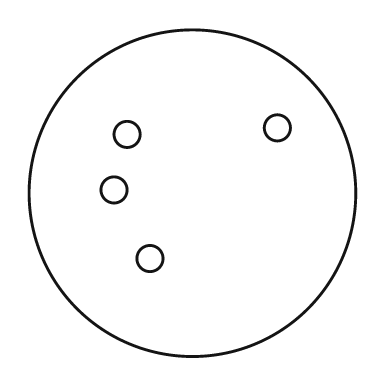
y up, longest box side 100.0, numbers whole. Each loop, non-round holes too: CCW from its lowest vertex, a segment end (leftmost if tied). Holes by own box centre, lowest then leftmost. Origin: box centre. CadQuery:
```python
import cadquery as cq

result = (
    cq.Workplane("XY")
    .moveTo(0.0, 0.0)
    .circle(50.0)
    .moveTo(-13.0, -20.0)
    .circle(4.0)
    .moveTo(-24.0, 1.0)
    .circle(4.0)
    .moveTo(-20.0, 18.0)
    .circle(4.0)
    .moveTo(26.0, 20.0)
    .circle(4.0)
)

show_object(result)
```